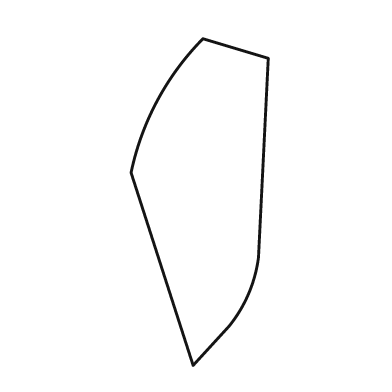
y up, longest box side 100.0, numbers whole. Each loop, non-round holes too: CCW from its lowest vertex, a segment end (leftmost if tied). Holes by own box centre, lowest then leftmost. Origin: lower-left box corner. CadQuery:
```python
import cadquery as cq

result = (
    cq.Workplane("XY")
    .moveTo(19.0, 0.0)
    .lineTo(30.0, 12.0)
    .threePointArc((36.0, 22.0), (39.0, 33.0))
    .lineTo(42.0, 94.0)
    .lineTo(22.0, 100.0)
    .threePointArc((8.0, 81.0), (0.0, 59.0))
    .close()
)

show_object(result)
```